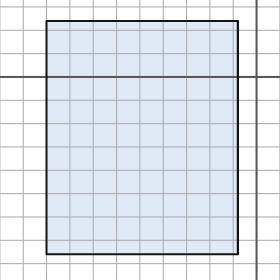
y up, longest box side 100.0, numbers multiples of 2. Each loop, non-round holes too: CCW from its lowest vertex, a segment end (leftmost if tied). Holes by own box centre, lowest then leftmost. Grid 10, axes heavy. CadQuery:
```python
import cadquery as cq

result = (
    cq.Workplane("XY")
    .moveTo(-90.0, -76.0)
    .lineTo(-8.0, -76.0)
    .lineTo(-8.0, 24.0)
    .lineTo(-90.0, 24.0)
    .close()
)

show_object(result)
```